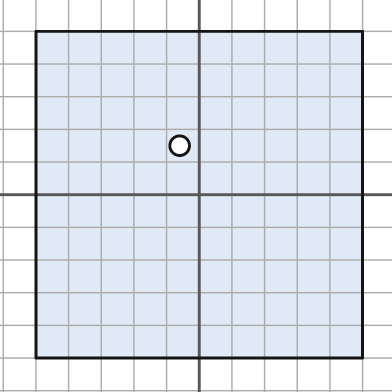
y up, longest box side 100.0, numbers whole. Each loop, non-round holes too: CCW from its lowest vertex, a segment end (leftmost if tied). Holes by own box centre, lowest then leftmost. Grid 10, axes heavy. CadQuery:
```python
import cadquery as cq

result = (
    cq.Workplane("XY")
    .moveTo(-50.0, -50.0)
    .lineTo(50.0, -50.0)
    .lineTo(50.0, 50.0)
    .lineTo(-50.0, 50.0)
    .close()
    .moveTo(-6.0, 15.0)
    .circle(3.0)
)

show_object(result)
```